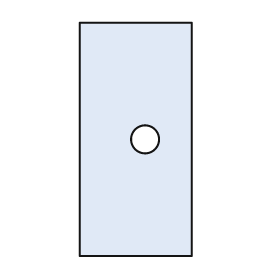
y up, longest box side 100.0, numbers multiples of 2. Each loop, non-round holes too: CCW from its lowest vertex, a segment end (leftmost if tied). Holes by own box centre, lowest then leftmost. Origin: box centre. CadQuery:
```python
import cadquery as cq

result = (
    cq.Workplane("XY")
    .moveTo(-24.0, -50.0)
    .lineTo(24.0, -50.0)
    .lineTo(24.0, 50.0)
    .lineTo(-24.0, 50.0)
    .close()
    .moveTo(4.0, 0.0)
    .circle(6.0)
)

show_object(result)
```